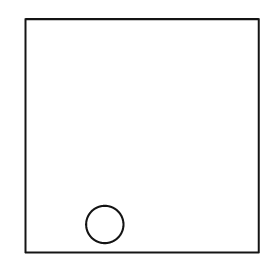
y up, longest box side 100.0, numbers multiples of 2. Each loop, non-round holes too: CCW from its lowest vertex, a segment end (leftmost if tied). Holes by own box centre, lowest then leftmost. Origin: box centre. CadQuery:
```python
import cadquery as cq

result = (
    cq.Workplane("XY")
    .moveTo(-50.0, -50.0)
    .lineTo(50.0, -50.0)
    .lineTo(50.0, 50.0)
    .lineTo(-50.0, 50.0)
    .close()
    .moveTo(-16.0, -38.0)
    .circle(8.0)
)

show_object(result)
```